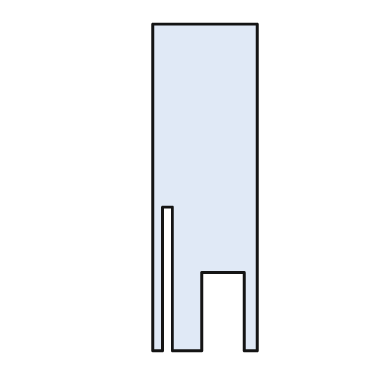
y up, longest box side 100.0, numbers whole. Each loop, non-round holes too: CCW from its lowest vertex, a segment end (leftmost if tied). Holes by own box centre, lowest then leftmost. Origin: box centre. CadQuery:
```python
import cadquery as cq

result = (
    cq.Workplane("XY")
    .moveTo(-16.0, -50.0)
    .lineTo(-13.0, -50.0)
    .lineTo(-13.0, -6.0)
    .lineTo(-10.0, -6.0)
    .lineTo(-10.0, -50.0)
    .lineTo(-1.0, -50.0)
    .lineTo(-1.0, -26.0)
    .lineTo(12.0, -26.0)
    .lineTo(12.0, -50.0)
    .lineTo(16.0, -50.0)
    .lineTo(16.0, 50.0)
    .lineTo(-16.0, 50.0)
    .close()
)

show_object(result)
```